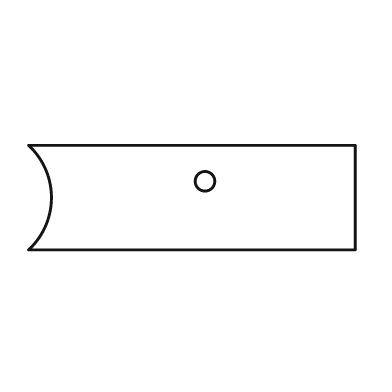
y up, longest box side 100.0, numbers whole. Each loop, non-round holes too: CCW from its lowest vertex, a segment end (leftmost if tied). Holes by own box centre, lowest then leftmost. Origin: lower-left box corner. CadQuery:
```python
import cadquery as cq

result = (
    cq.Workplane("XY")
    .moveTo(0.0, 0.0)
    .lineTo(100.0, 0.0)
    .lineTo(100.0, 32.0)
    .lineTo(0.0, 32.0)
    .threePointArc((7.0, 16.0), (0.0, 0.0))
    .close()
    .moveTo(54.0, 21.0)
    .circle(3.0)
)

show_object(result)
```